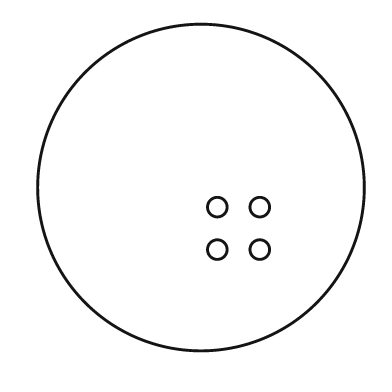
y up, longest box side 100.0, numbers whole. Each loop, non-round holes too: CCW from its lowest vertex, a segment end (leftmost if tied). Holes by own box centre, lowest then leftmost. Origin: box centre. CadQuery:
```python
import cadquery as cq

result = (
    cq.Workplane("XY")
    .moveTo(0.0, 0.0)
    .circle(50.0)
    .moveTo(5.0, -19.0)
    .circle(3.0)
    .moveTo(18.0, -19.0)
    .circle(3.0)
    .moveTo(5.0, -6.0)
    .circle(3.0)
    .moveTo(18.0, -6.0)
    .circle(3.0)
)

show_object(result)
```